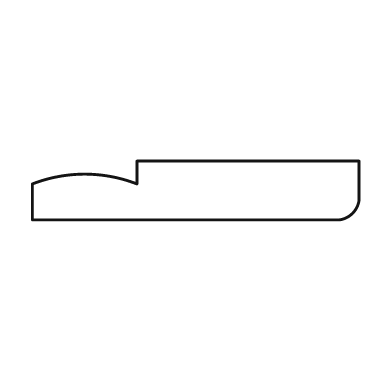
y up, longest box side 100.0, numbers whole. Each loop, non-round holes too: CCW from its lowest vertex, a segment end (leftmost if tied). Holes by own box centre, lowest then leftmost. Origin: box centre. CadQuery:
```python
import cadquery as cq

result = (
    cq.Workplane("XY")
    .moveTo(-50.0, -9.0)
    .lineTo(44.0, -9.0)
    .threePointArc((48.0, -7.0), (50.0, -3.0))
    .lineTo(50.0, 9.0)
    .lineTo(-18.0, 9.0)
    .lineTo(-18.0, 2.0)
    .threePointArc((-34.0, 5.0), (-50.0, 2.0))
    .close()
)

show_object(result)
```